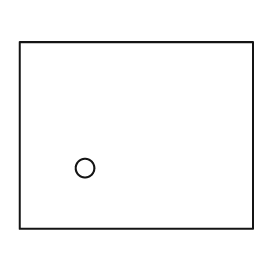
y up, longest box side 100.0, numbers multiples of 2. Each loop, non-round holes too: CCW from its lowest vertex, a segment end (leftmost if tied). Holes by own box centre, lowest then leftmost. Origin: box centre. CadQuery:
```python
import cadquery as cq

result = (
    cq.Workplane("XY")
    .moveTo(-50.0, -40.0)
    .lineTo(50.0, -40.0)
    .lineTo(50.0, 40.0)
    .lineTo(-50.0, 40.0)
    .close()
    .moveTo(-22.0, -14.0)
    .circle(4.0)
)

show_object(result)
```